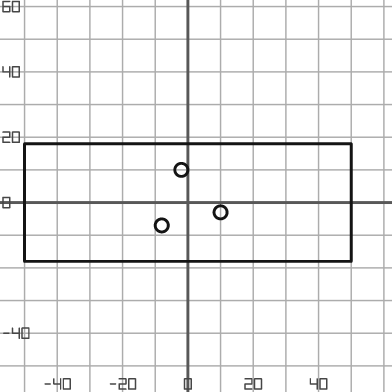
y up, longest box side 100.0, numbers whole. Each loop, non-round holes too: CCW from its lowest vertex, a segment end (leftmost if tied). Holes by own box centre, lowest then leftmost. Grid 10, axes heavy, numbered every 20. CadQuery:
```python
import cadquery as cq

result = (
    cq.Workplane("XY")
    .moveTo(-50.0, -18.0)
    .lineTo(50.0, -18.0)
    .lineTo(50.0, 18.0)
    .lineTo(-50.0, 18.0)
    .close()
    .moveTo(-8.0, -7.0)
    .circle(2.0)
    .moveTo(10.0, -3.0)
    .circle(2.0)
    .moveTo(-2.0, 10.0)
    .circle(2.0)
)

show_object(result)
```